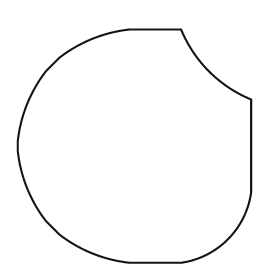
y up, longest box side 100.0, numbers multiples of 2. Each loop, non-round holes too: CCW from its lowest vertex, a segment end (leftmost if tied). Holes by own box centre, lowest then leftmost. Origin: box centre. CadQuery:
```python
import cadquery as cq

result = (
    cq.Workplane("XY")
    .moveTo(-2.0, -50.0)
    .lineTo(20.0, -50.0)
    .threePointArc((40.0, -40.0), (50.0, -20.0))
    .lineTo(50.0, 20.0)
    .threePointArc((32.0, 32.0), (20.0, 50.0))
    .lineTo(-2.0, 50.0)
    .threePointArc((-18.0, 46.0), (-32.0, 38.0))
    .lineTo(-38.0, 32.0)
    .threePointArc((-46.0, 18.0), (-50.0, 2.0))
    .lineTo(-50.0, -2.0)
    .threePointArc((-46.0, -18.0), (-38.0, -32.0))
    .lineTo(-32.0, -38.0)
    .threePointArc((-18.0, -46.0), (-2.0, -50.0))
    .close()
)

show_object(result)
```